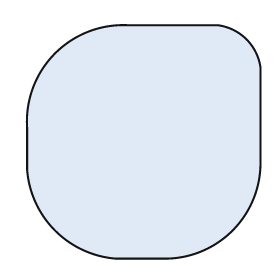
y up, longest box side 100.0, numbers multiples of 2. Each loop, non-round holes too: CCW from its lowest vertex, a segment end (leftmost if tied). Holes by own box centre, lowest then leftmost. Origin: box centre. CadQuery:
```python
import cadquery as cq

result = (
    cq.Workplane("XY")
    .moveTo(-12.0, -50.0)
    .lineTo(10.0, -50.0)
    .threePointArc((38.0, -38.0), (50.0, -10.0))
    .lineTo(50.0, 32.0)
    .threePointArc((44.0, 44.0), (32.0, 50.0))
    .lineTo(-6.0, 50.0)
    .threePointArc((-38.0, 38.0), (-50.0, 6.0))
    .lineTo(-50.0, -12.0)
    .threePointArc((-38.0, -38.0), (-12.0, -50.0))
    .close()
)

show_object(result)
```